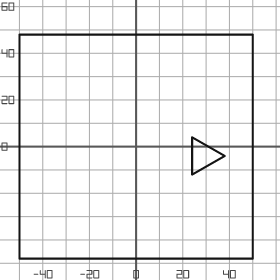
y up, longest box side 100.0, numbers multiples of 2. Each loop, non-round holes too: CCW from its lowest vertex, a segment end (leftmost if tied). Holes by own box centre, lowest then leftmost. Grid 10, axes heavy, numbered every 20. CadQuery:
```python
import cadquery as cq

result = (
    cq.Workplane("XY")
    .moveTo(-50.0, -48.0)
    .lineTo(50.0, -48.0)
    .lineTo(50.0, 48.0)
    .lineTo(-50.0, 48.0)
    .close()
    .moveTo(24.0, -12.0)
    .lineTo(38.0, -4.0)
    .lineTo(24.0, 4.0)
    .close()
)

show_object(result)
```